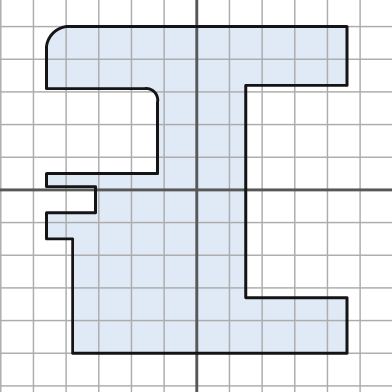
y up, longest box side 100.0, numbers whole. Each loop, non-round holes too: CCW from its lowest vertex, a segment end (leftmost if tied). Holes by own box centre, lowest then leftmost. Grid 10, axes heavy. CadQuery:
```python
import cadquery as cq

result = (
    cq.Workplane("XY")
    .moveTo(-38.0, -50.0)
    .lineTo(46.0, -50.0)
    .lineTo(46.0, -33.0)
    .lineTo(15.0, -33.0)
    .lineTo(15.0, 32.0)
    .lineTo(46.0, 32.0)
    .lineTo(46.0, 50.0)
    .lineTo(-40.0, 50.0)
    .threePointArc((-44.0, 48.0), (-46.0, 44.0))
    .lineTo(-46.0, 31.0)
    .lineTo(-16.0, 31.0)
    .threePointArc((-13.0, 30.0), (-12.0, 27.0))
    .lineTo(-12.0, 5.0)
    .lineTo(-46.0, 5.0)
    .lineTo(-46.0, 1.0)
    .lineTo(-31.0, 1.0)
    .lineTo(-31.0, -7.0)
    .lineTo(-46.0, -7.0)
    .lineTo(-46.0, -15.0)
    .lineTo(-38.0, -15.0)
    .close()
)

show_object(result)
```